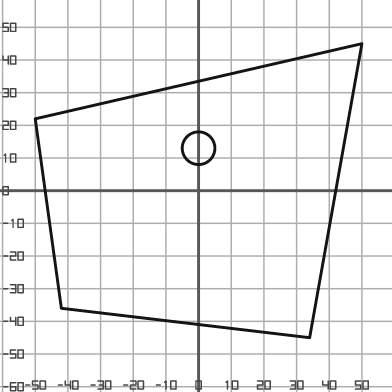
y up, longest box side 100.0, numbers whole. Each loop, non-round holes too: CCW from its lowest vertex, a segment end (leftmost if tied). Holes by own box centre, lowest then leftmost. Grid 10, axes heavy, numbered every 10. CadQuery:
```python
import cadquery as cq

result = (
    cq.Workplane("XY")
    .moveTo(34.0, -45.0)
    .lineTo(50.0, 45.0)
    .lineTo(-50.0, 22.0)
    .lineTo(-42.0, -36.0)
    .close()
    .moveTo(0.0, 13.0)
    .circle(5.0)
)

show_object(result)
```